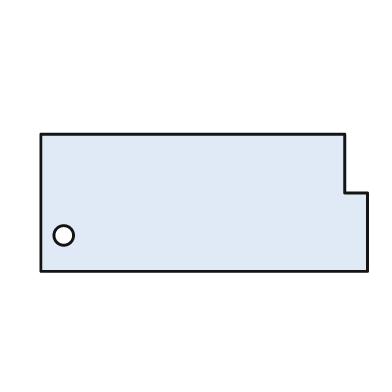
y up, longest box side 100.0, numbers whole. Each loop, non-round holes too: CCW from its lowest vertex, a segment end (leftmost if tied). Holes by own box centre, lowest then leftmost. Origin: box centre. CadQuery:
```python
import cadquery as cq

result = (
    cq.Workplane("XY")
    .moveTo(-50.0, -21.0)
    .lineTo(50.0, -21.0)
    .lineTo(50.0, 3.0)
    .lineTo(43.0, 3.0)
    .lineTo(43.0, 21.0)
    .lineTo(-50.0, 21.0)
    .close()
    .moveTo(-43.0, -10.0)
    .circle(3.0)
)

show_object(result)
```